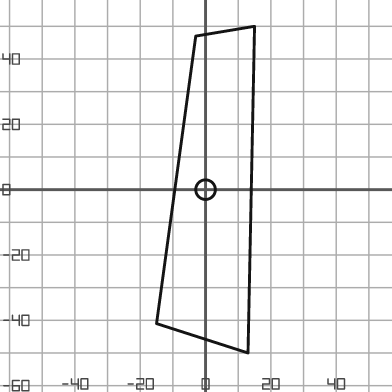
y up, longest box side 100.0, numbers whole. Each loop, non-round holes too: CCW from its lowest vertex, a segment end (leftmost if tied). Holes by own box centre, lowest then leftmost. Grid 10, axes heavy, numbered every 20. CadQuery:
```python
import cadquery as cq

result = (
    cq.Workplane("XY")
    .moveTo(13.0, -50.0)
    .lineTo(15.0, 50.0)
    .lineTo(-3.0, 47.0)
    .lineTo(-15.0, -41.0)
    .close()
    .moveTo(0.0, 0.0)
    .circle(3.0)
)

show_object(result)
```